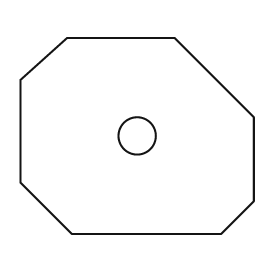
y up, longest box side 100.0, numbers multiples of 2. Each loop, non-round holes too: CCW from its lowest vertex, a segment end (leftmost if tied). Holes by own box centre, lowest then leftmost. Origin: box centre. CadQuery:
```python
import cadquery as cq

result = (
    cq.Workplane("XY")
    .moveTo(-28.0, -42.0)
    .lineTo(36.0, -42.0)
    .lineTo(50.0, -28.0)
    .lineTo(50.0, 8.0)
    .lineTo(16.0, 42.0)
    .lineTo(-30.0, 42.0)
    .lineTo(-50.0, 24.0)
    .lineTo(-50.0, -20.0)
    .close()
    .moveTo(0.0, 0.0)
    .circle(8.0)
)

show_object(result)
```